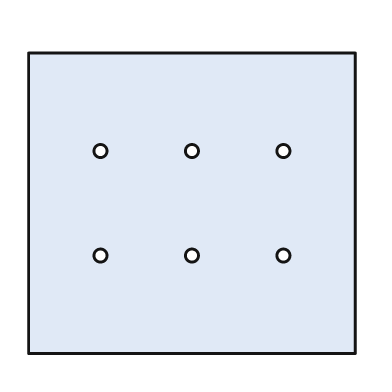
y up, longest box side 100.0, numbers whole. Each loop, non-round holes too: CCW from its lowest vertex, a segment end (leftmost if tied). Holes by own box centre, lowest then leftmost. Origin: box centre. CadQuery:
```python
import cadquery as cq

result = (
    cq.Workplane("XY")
    .moveTo(-50.0, -46.0)
    .lineTo(50.0, -46.0)
    .lineTo(50.0, 46.0)
    .lineTo(-50.0, 46.0)
    .close()
    .moveTo(-28.0, -16.0)
    .circle(2.0)
    .moveTo(0.0, -16.0)
    .circle(2.0)
    .moveTo(28.0, -16.0)
    .circle(2.0)
    .moveTo(-28.0, 16.0)
    .circle(2.0)
    .moveTo(0.0, 16.0)
    .circle(2.0)
    .moveTo(28.0, 16.0)
    .circle(2.0)
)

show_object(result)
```